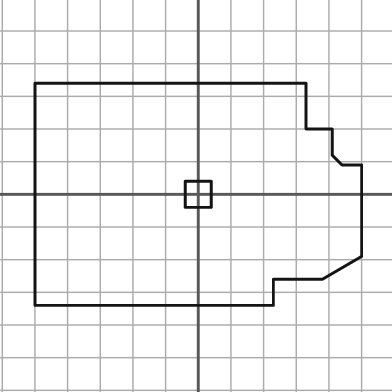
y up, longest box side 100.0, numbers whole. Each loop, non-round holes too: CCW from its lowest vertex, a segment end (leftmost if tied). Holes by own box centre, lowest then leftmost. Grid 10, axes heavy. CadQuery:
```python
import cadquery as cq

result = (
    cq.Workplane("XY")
    .moveTo(-50.0, -34.0)
    .lineTo(23.0, -34.0)
    .lineTo(23.0, -26.0)
    .lineTo(38.0, -26.0)
    .lineTo(50.0, -19.0)
    .lineTo(50.0, 9.0)
    .lineTo(44.0, 9.0)
    .lineTo(41.0, 12.0)
    .lineTo(41.0, 20.0)
    .lineTo(33.0, 20.0)
    .lineTo(33.0, 34.0)
    .lineTo(-50.0, 34.0)
    .close()
    .moveTo(-4.0, -4.0)
    .lineTo(4.0, -4.0)
    .lineTo(4.0, 4.0)
    .lineTo(-4.0, 4.0)
    .close()
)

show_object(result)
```